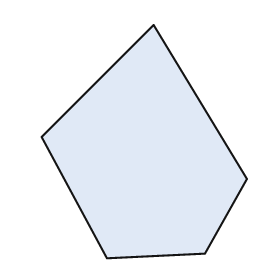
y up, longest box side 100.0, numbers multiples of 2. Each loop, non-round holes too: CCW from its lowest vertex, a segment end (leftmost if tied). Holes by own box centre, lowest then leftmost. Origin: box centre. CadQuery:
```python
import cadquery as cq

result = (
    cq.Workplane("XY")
    .moveTo(-16.0, -50.0)
    .lineTo(26.0, -48.0)
    .lineTo(44.0, -16.0)
    .lineTo(4.0, 50.0)
    .lineTo(-44.0, 2.0)
    .close()
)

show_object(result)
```